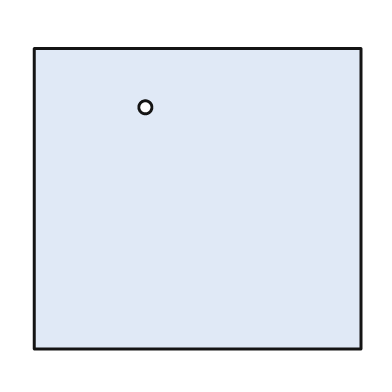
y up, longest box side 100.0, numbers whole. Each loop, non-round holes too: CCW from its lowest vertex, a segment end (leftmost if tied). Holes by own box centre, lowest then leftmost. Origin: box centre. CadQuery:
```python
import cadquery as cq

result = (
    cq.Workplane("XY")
    .moveTo(-50.0, -46.0)
    .lineTo(50.0, -46.0)
    .lineTo(50.0, 46.0)
    .lineTo(-50.0, 46.0)
    .close()
    .moveTo(-16.0, 28.0)
    .circle(2.0)
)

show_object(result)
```